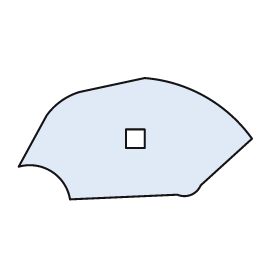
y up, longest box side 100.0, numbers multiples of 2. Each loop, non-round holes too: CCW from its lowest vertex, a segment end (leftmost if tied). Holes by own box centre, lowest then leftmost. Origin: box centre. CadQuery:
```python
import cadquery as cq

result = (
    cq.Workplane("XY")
    .moveTo(-28.0, -26.0)
    .lineTo(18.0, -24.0)
    .threePointArc((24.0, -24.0), (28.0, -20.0))
    .lineTo(50.0, 0.0)
    .threePointArc((30.0, 18.0), (4.0, 26.0))
    .lineTo(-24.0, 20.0)
    .threePointArc((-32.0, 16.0), (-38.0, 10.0))
    .lineTo(-50.0, -12.0)
    .threePointArc((-36.0, -14.0), (-28.0, -26.0))
    .close()
    .moveTo(-4.0, -4.0)
    .lineTo(4.0, -4.0)
    .lineTo(4.0, 4.0)
    .lineTo(-4.0, 4.0)
    .close()
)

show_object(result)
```